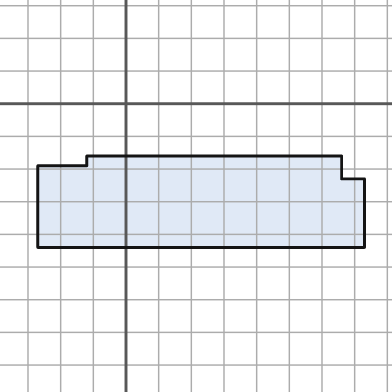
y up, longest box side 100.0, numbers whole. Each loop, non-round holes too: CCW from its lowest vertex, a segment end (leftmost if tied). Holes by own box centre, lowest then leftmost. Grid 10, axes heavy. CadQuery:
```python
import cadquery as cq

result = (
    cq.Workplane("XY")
    .moveTo(-27.0, -44.0)
    .lineTo(73.0, -44.0)
    .lineTo(73.0, -23.0)
    .lineTo(66.0, -23.0)
    .lineTo(66.0, -16.0)
    .lineTo(-12.0, -16.0)
    .lineTo(-12.0, -19.0)
    .lineTo(-27.0, -19.0)
    .close()
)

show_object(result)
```